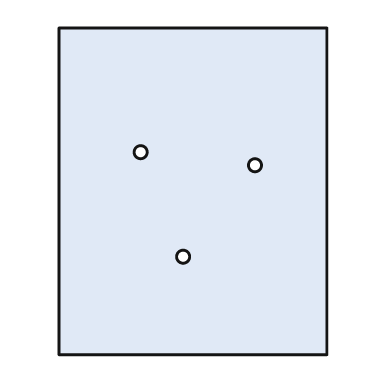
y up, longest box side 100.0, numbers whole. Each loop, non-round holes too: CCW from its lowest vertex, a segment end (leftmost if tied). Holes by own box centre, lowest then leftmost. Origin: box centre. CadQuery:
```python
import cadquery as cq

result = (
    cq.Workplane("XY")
    .moveTo(-41.0, -50.0)
    .lineTo(41.0, -50.0)
    .lineTo(41.0, 50.0)
    .lineTo(-41.0, 50.0)
    .close()
    .moveTo(-3.0, -20.0)
    .circle(2.0)
    .moveTo(19.0, 8.0)
    .circle(2.0)
    .moveTo(-16.0, 12.0)
    .circle(2.0)
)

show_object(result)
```